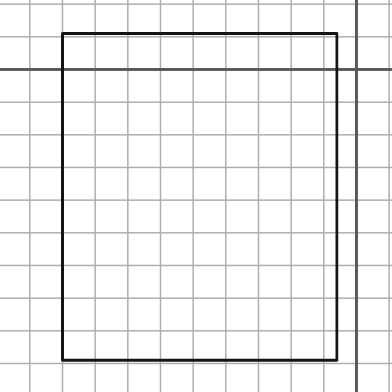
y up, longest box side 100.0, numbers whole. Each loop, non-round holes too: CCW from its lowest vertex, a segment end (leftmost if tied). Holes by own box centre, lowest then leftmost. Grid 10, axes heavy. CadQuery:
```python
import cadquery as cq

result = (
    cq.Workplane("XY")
    .moveTo(-90.0, -89.0)
    .lineTo(-6.0, -89.0)
    .lineTo(-6.0, 11.0)
    .lineTo(-90.0, 11.0)
    .close()
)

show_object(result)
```